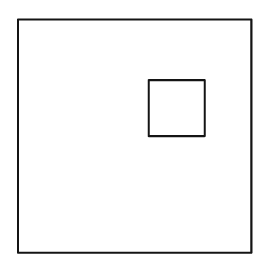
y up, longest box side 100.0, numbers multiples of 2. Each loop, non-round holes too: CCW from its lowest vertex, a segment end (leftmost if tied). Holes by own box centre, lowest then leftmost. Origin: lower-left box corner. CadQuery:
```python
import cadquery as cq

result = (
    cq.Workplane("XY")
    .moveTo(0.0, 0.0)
    .lineTo(100.0, 0.0)
    .lineTo(100.0, 100.0)
    .lineTo(0.0, 100.0)
    .close()
    .moveTo(56.0, 50.0)
    .lineTo(80.0, 50.0)
    .lineTo(80.0, 74.0)
    .lineTo(56.0, 74.0)
    .close()
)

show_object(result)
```